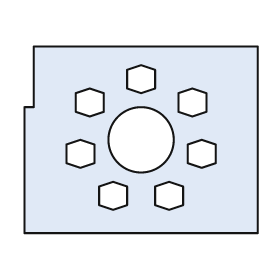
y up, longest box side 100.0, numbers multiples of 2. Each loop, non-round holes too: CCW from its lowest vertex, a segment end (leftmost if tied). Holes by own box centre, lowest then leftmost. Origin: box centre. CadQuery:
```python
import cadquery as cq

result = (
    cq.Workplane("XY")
    .moveTo(-50.0, -40.0)
    .lineTo(50.0, -40.0)
    .lineTo(50.0, 40.0)
    .lineTo(-46.0, 40.0)
    .lineTo(-46.0, 14.0)
    .lineTo(-50.0, 14.0)
    .close()
    .moveTo(-12.0, -30.0)
    .lineTo(-6.0, -28.0)
    .lineTo(-6.0, -20.0)
    .lineTo(-12.0, -18.0)
    .lineTo(-18.0, -20.0)
    .lineTo(-18.0, -28.0)
    .close()
    .moveTo(12.0, -30.0)
    .lineTo(18.0, -28.0)
    .lineTo(18.0, -20.0)
    .lineTo(12.0, -18.0)
    .lineTo(6.0, -20.0)
    .lineTo(6.0, -28.0)
    .close()
    .moveTo(-26.0, -12.0)
    .lineTo(-20.0, -10.0)
    .lineTo(-20.0, -2.0)
    .lineTo(-26.0, 0.0)
    .lineTo(-32.0, -2.0)
    .lineTo(-32.0, -10.0)
    .close()
    .moveTo(26.0, -12.0)
    .lineTo(32.0, -10.0)
    .lineTo(32.0, -2.0)
    .lineTo(26.0, 0.0)
    .lineTo(20.0, -2.0)
    .lineTo(20.0, -10.0)
    .close()
    .moveTo(0.0, 0.0)
    .circle(14.0)
    .moveTo(-22.0, 10.0)
    .lineTo(-16.0, 12.0)
    .lineTo(-16.0, 20.0)
    .lineTo(-22.0, 22.0)
    .lineTo(-28.0, 20.0)
    .lineTo(-28.0, 12.0)
    .close()
    .moveTo(22.0, 10.0)
    .lineTo(28.0, 12.0)
    .lineTo(28.0, 20.0)
    .lineTo(22.0, 22.0)
    .lineTo(16.0, 20.0)
    .lineTo(16.0, 12.0)
    .close()
    .moveTo(0.0, 20.0)
    .lineTo(6.0, 22.0)
    .lineTo(6.0, 30.0)
    .lineTo(0.0, 32.0)
    .lineTo(-6.0, 30.0)
    .lineTo(-6.0, 22.0)
    .close()
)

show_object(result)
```